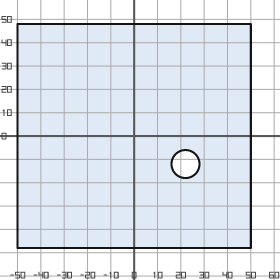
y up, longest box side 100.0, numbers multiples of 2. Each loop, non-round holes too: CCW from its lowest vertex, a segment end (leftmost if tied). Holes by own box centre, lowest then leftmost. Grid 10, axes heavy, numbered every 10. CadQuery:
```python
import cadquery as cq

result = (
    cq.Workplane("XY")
    .moveTo(-50.0, -48.0)
    .lineTo(50.0, -48.0)
    .lineTo(50.0, 48.0)
    .lineTo(-50.0, 48.0)
    .close()
    .moveTo(22.0, -12.0)
    .circle(6.0)
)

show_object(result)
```